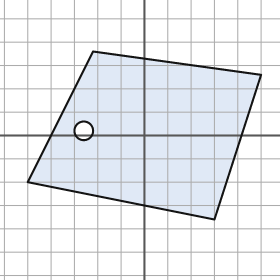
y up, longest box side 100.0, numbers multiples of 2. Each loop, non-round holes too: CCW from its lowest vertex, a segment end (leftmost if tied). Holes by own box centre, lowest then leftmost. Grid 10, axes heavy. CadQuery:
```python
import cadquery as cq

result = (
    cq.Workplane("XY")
    .moveTo(30.0, -36.0)
    .lineTo(50.0, 26.0)
    .lineTo(-22.0, 36.0)
    .lineTo(-50.0, -20.0)
    .close()
    .moveTo(-26.0, 2.0)
    .circle(4.0)
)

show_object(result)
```